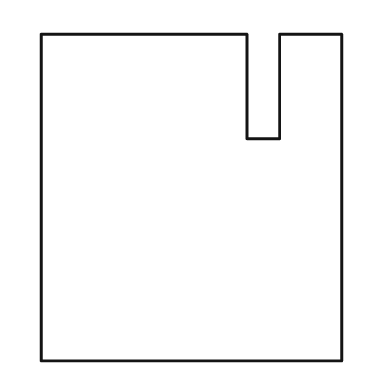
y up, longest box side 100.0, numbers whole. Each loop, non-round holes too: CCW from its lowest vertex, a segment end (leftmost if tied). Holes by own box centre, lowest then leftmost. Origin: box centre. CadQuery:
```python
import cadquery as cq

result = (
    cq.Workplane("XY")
    .moveTo(-46.0, -50.0)
    .lineTo(46.0, -50.0)
    .lineTo(46.0, 50.0)
    .lineTo(27.0, 50.0)
    .lineTo(27.0, 18.0)
    .lineTo(17.0, 18.0)
    .lineTo(17.0, 50.0)
    .lineTo(-46.0, 50.0)
    .close()
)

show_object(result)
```